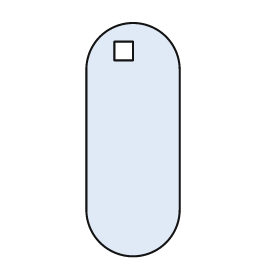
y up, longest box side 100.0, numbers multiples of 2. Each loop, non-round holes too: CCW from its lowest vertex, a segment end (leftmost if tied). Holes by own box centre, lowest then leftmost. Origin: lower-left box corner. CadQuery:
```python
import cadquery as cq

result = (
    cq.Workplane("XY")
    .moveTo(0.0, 20.0)
    .threePointArc((20.0, 0.0), (40.0, 20.0))
    .lineTo(40.0, 80.0)
    .threePointArc((20.0, 100.0), (0.0, 80.0))
    .close()
    .moveTo(12.0, 84.0)
    .lineTo(20.0, 84.0)
    .lineTo(20.0, 92.0)
    .lineTo(12.0, 92.0)
    .close()
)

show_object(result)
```